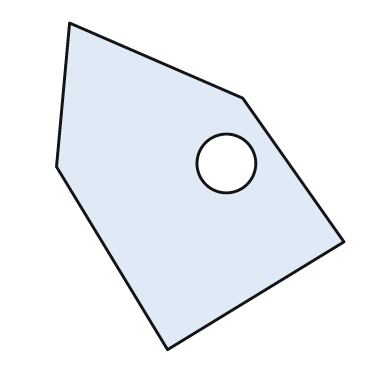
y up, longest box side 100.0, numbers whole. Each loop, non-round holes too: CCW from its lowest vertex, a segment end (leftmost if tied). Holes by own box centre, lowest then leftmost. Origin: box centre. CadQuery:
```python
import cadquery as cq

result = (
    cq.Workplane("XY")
    .moveTo(-10.0, -50.0)
    .lineTo(44.0, -17.0)
    .lineTo(13.0, 27.0)
    .lineTo(-40.0, 50.0)
    .lineTo(-44.0, 6.0)
    .close()
    .moveTo(8.0, 7.0)
    .circle(9.0)
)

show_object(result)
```